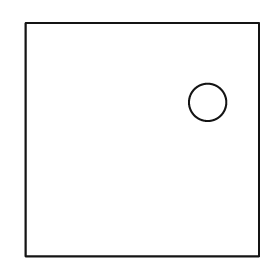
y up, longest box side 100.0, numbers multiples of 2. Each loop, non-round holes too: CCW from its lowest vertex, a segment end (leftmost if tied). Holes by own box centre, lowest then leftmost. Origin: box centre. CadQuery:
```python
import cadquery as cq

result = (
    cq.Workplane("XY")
    .moveTo(-50.0, -50.0)
    .lineTo(50.0, -50.0)
    .lineTo(50.0, 50.0)
    .lineTo(-50.0, 50.0)
    .close()
    .moveTo(28.0, 16.0)
    .circle(8.0)
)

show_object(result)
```